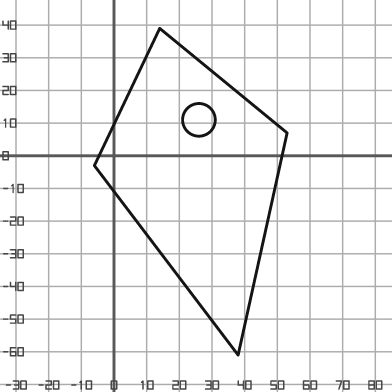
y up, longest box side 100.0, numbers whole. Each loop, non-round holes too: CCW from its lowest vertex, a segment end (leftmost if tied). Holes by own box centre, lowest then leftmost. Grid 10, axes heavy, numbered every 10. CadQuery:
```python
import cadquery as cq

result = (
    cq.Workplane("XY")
    .moveTo(38.0, -61.0)
    .lineTo(53.0, 7.0)
    .lineTo(14.0, 39.0)
    .lineTo(-6.0, -3.0)
    .close()
    .moveTo(26.0, 11.0)
    .circle(5.0)
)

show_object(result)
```